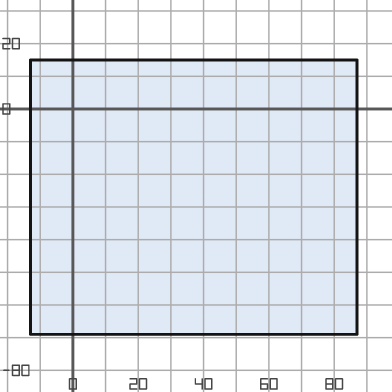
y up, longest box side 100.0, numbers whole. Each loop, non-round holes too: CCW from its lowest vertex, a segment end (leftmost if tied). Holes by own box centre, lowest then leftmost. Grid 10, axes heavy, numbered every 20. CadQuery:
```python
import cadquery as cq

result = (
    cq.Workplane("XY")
    .moveTo(-13.0, -69.0)
    .lineTo(87.0, -69.0)
    .lineTo(87.0, 15.0)
    .lineTo(-13.0, 15.0)
    .close()
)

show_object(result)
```